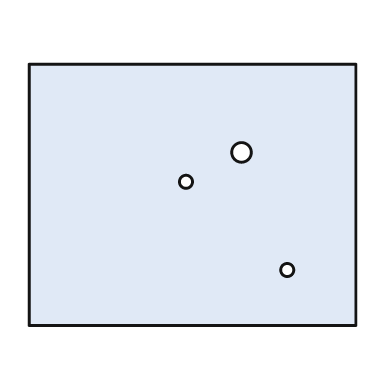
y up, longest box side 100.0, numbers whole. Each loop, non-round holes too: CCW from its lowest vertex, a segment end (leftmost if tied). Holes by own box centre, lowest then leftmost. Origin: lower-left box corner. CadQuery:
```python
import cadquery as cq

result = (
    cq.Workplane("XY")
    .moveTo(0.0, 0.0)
    .lineTo(100.0, 0.0)
    .lineTo(100.0, 80.0)
    .lineTo(0.0, 80.0)
    .close()
    .moveTo(79.0, 17.0)
    .circle(2.0)
    .moveTo(48.0, 44.0)
    .circle(2.0)
    .moveTo(65.0, 53.0)
    .circle(3.0)
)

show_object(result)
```